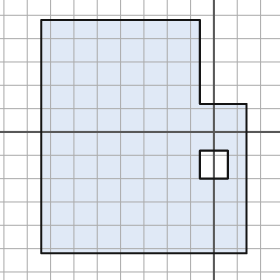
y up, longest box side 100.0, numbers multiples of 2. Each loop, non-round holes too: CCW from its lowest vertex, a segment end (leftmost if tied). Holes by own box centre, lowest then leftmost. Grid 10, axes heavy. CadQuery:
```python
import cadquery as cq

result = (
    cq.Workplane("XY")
    .moveTo(-74.0, -52.0)
    .lineTo(14.0, -52.0)
    .lineTo(14.0, 12.0)
    .lineTo(-6.0, 12.0)
    .lineTo(-6.0, 48.0)
    .lineTo(-74.0, 48.0)
    .close()
    .moveTo(-6.0, -20.0)
    .lineTo(6.0, -20.0)
    .lineTo(6.0, -8.0)
    .lineTo(-6.0, -8.0)
    .close()
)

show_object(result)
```